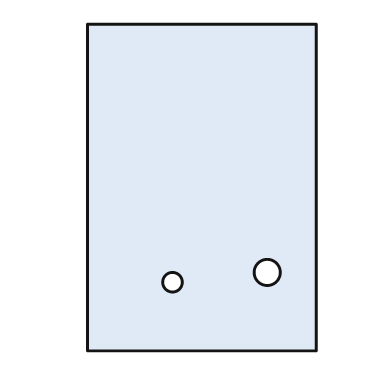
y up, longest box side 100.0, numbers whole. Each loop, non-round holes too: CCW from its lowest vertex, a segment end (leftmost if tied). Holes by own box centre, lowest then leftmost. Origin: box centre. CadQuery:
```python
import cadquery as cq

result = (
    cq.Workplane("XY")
    .moveTo(-35.0, -50.0)
    .lineTo(35.0, -50.0)
    .lineTo(35.0, 50.0)
    .lineTo(-35.0, 50.0)
    .close()
    .moveTo(-9.0, -29.0)
    .circle(3.0)
    .moveTo(20.0, -26.0)
    .circle(4.0)
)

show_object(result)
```